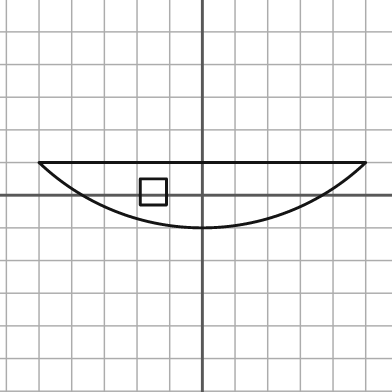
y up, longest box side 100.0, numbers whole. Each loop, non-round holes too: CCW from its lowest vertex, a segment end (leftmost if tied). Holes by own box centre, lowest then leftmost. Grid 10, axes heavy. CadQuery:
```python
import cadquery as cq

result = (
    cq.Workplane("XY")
    .moveTo(-50.0, 10.0)
    .threePointArc((0.0, -10.0), (50.0, 10.0))
    .close()
    .moveTo(-19.0, -3.0)
    .lineTo(-11.0, -3.0)
    .lineTo(-11.0, 5.0)
    .lineTo(-19.0, 5.0)
    .close()
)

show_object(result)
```